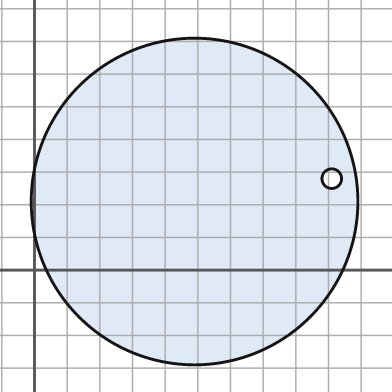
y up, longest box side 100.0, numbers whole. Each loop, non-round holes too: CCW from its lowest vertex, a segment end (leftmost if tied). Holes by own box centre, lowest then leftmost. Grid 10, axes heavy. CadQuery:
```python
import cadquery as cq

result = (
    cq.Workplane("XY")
    .moveTo(49.0, 21.0)
    .circle(50.0)
    .moveTo(91.0, 28.0)
    .circle(3.0)
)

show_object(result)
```